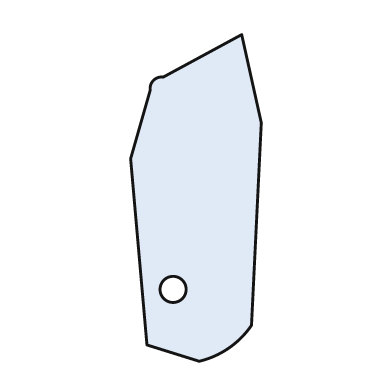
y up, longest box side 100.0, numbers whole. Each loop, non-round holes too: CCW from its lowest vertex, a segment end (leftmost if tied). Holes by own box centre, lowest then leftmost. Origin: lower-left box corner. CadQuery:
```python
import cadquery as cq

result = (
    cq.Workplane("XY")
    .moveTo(21.0, 0.0)
    .threePointArc((30.0, 4.0), (37.0, 11.0))
    .lineTo(40.0, 73.0)
    .lineTo(34.0, 100.0)
    .lineTo(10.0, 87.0)
    .threePointArc((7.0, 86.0), (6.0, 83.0))
    .lineTo(0.0, 62.0)
    .lineTo(5.0, 5.0)
    .close()
    .moveTo(13.0, 22.0)
    .circle(4.0)
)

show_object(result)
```